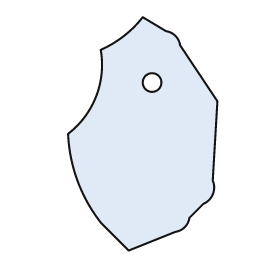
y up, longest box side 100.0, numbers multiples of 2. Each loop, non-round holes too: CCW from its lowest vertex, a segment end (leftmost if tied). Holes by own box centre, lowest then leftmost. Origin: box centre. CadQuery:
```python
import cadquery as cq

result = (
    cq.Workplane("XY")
    .moveTo(-6.0, -50.0)
    .lineTo(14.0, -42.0)
    .threePointArc((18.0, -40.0), (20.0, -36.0))
    .lineTo(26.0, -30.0)
    .threePointArc((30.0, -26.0), (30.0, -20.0))
    .lineTo(32.0, 14.0)
    .lineTo(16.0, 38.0)
    .threePointArc((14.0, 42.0), (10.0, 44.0))
    .lineTo(0.0, 50.0)
    .threePointArc((-8.0, 42.0), (-18.0, 36.0))
    .threePointArc((-20.0, 16.0), (-32.0, 0.0))
    .threePointArc((-28.0, -20.0), (-18.0, -38.0))
    .close()
    .moveTo(4.0, 22.0)
    .circle(4.0)
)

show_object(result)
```